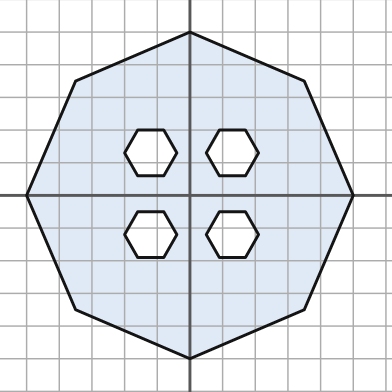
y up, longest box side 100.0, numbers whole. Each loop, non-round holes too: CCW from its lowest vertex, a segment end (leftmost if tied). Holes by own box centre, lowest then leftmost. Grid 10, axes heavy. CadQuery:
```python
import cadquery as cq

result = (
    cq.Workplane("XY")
    .moveTo(0.0, -50.0)
    .lineTo(35.0, -35.0)
    .lineTo(50.0, 0.0)
    .lineTo(35.0, 35.0)
    .lineTo(0.0, 50.0)
    .lineTo(-35.0, 35.0)
    .lineTo(-50.0, 0.0)
    .lineTo(-35.0, -35.0)
    .close()
    .moveTo(-16.0, -19.0)
    .lineTo(-8.0, -19.0)
    .lineTo(-4.0, -12.0)
    .lineTo(-8.0, -5.0)
    .lineTo(-16.0, -5.0)
    .lineTo(-20.0, -12.0)
    .close()
    .moveTo(9.0, -19.0)
    .lineTo(17.0, -19.0)
    .lineTo(21.0, -12.0)
    .lineTo(17.0, -5.0)
    .lineTo(9.0, -5.0)
    .lineTo(5.0, -12.0)
    .close()
    .moveTo(-16.0, 6.0)
    .lineTo(-8.0, 6.0)
    .lineTo(-4.0, 13.0)
    .lineTo(-8.0, 20.0)
    .lineTo(-16.0, 20.0)
    .lineTo(-20.0, 13.0)
    .close()
    .moveTo(9.0, 6.0)
    .lineTo(17.0, 6.0)
    .lineTo(21.0, 13.0)
    .lineTo(17.0, 20.0)
    .lineTo(9.0, 20.0)
    .lineTo(5.0, 13.0)
    .close()
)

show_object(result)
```